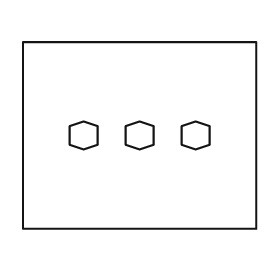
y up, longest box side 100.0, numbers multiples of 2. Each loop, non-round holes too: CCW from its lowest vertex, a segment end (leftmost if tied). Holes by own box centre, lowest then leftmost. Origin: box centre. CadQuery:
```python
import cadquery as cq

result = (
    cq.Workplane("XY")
    .moveTo(-50.0, -40.0)
    .lineTo(50.0, -40.0)
    .lineTo(50.0, 40.0)
    .lineTo(-50.0, 40.0)
    .close()
    .moveTo(-24.0, -6.0)
    .lineTo(-18.0, -4.0)
    .lineTo(-18.0, 4.0)
    .lineTo(-24.0, 6.0)
    .lineTo(-30.0, 4.0)
    .lineTo(-30.0, -4.0)
    .close()
    .moveTo(0.0, -6.0)
    .lineTo(6.0, -4.0)
    .lineTo(6.0, 4.0)
    .lineTo(0.0, 6.0)
    .lineTo(-6.0, 4.0)
    .lineTo(-6.0, -4.0)
    .close()
    .moveTo(24.0, -6.0)
    .lineTo(30.0, -4.0)
    .lineTo(30.0, 4.0)
    .lineTo(24.0, 6.0)
    .lineTo(18.0, 4.0)
    .lineTo(18.0, -4.0)
    .close()
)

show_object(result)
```